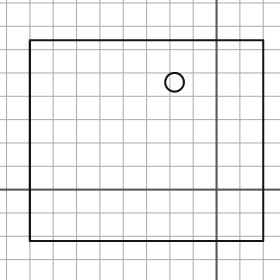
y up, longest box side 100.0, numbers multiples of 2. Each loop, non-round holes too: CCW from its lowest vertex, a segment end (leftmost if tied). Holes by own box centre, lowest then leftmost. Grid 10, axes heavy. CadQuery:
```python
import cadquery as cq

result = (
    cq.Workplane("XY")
    .moveTo(-80.0, -22.0)
    .lineTo(20.0, -22.0)
    .lineTo(20.0, 64.0)
    .lineTo(-80.0, 64.0)
    .close()
    .moveTo(-18.0, 46.0)
    .circle(4.0)
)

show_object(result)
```